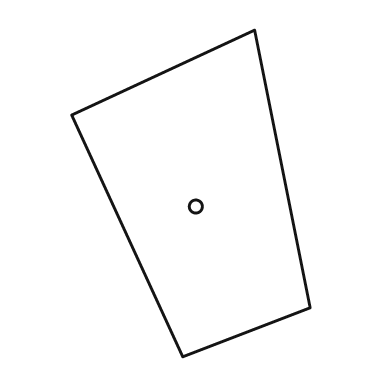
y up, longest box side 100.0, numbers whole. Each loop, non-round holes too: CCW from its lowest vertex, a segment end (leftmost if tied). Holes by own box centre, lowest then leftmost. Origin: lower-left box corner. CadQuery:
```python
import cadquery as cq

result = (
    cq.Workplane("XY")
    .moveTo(34.0, 0.0)
    .lineTo(73.0, 15.0)
    .lineTo(56.0, 100.0)
    .lineTo(0.0, 74.0)
    .close()
    .moveTo(38.0, 46.0)
    .circle(2.0)
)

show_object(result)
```